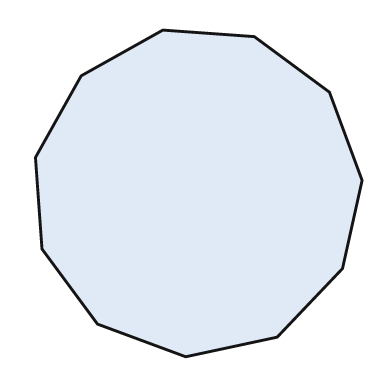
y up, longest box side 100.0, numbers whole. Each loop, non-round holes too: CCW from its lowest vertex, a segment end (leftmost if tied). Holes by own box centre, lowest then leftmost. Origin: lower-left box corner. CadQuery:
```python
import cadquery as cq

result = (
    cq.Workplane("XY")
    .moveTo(46.0, 0.0)
    .lineTo(74.0, 6.0)
    .lineTo(94.0, 27.0)
    .lineTo(100.0, 54.0)
    .lineTo(90.0, 81.0)
    .lineTo(67.0, 98.0)
    .lineTo(39.0, 100.0)
    .lineTo(14.0, 86.0)
    .lineTo(0.0, 61.0)
    .lineTo(2.0, 33.0)
    .lineTo(19.0, 10.0)
    .close()
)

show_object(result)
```